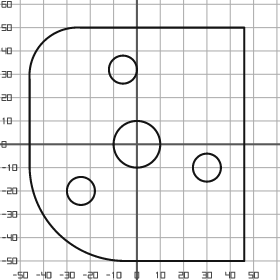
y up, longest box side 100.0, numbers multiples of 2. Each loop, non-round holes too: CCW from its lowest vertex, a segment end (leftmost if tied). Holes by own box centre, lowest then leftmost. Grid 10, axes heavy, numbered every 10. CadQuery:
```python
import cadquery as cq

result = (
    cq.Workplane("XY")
    .moveTo(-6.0, -50.0)
    .lineTo(46.0, -50.0)
    .lineTo(46.0, 50.0)
    .lineTo(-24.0, 50.0)
    .threePointArc((-40.0, 44.0), (-46.0, 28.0))
    .lineTo(-46.0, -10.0)
    .threePointArc((-34.0, -38.0), (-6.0, -50.0))
    .close()
    .moveTo(-24.0, -20.0)
    .circle(6.0)
    .moveTo(30.0, -10.0)
    .circle(6.0)
    .moveTo(0.0, 0.0)
    .circle(10.0)
    .moveTo(-6.0, 32.0)
    .circle(6.0)
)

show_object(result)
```